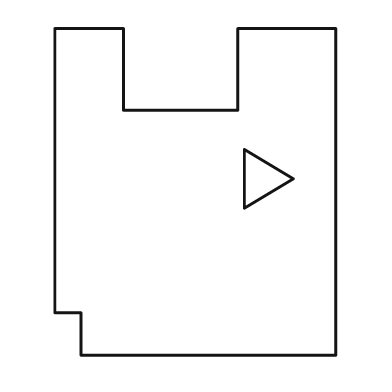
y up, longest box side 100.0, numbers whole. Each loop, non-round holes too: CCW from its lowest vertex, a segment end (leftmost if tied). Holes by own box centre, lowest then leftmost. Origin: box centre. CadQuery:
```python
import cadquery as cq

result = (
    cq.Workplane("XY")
    .moveTo(-35.0, -50.0)
    .lineTo(43.0, -50.0)
    .lineTo(43.0, 50.0)
    .lineTo(13.0, 50.0)
    .lineTo(13.0, 25.0)
    .lineTo(-22.0, 25.0)
    .lineTo(-22.0, 50.0)
    .lineTo(-43.0, 50.0)
    .lineTo(-43.0, -37.0)
    .lineTo(-35.0, -37.0)
    .close()
    .moveTo(15.0, -5.0)
    .lineTo(30.0, 4.0)
    .lineTo(15.0, 13.0)
    .close()
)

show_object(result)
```